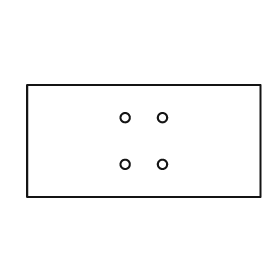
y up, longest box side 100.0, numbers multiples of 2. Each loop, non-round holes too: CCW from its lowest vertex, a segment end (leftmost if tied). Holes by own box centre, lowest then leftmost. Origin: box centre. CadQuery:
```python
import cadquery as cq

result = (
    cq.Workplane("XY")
    .moveTo(-50.0, -24.0)
    .lineTo(50.0, -24.0)
    .lineTo(50.0, 24.0)
    .lineTo(-50.0, 24.0)
    .close()
    .moveTo(-8.0, -10.0)
    .circle(2.0)
    .moveTo(8.0, -10.0)
    .circle(2.0)
    .moveTo(-8.0, 10.0)
    .circle(2.0)
    .moveTo(8.0, 10.0)
    .circle(2.0)
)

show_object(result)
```